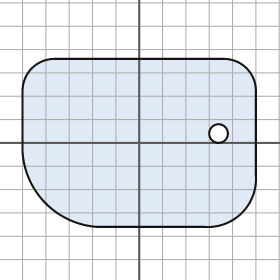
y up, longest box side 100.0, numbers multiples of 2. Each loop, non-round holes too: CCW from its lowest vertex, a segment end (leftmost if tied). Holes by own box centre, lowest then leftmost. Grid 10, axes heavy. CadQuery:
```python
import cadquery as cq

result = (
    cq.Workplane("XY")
    .moveTo(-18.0, -36.0)
    .lineTo(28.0, -36.0)
    .threePointArc((44.0, -30.0), (50.0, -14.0))
    .lineTo(50.0, 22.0)
    .threePointArc((46.0, 32.0), (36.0, 36.0))
    .lineTo(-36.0, 36.0)
    .threePointArc((-46.0, 32.0), (-50.0, 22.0))
    .lineTo(-50.0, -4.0)
    .threePointArc((-40.0, -26.0), (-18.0, -36.0))
    .close()
    .moveTo(34.0, 4.0)
    .circle(4.0)
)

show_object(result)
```